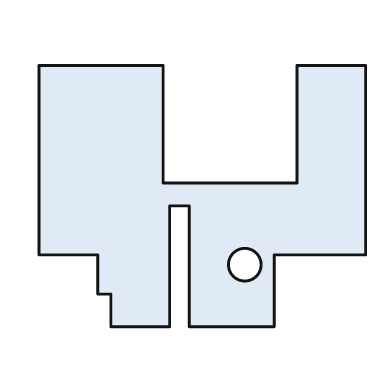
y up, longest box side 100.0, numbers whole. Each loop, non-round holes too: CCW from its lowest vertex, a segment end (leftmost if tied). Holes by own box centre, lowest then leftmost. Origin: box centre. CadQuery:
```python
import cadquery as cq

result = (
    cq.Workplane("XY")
    .moveTo(-28.0, -40.0)
    .lineTo(-10.0, -40.0)
    .lineTo(-10.0, -3.0)
    .lineTo(-4.0, -3.0)
    .lineTo(-4.0, -40.0)
    .lineTo(22.0, -40.0)
    .lineTo(22.0, -18.0)
    .lineTo(50.0, -18.0)
    .lineTo(50.0, 40.0)
    .lineTo(29.0, 40.0)
    .lineTo(29.0, 4.0)
    .lineTo(-12.0, 4.0)
    .lineTo(-12.0, 40.0)
    .lineTo(-50.0, 40.0)
    .lineTo(-50.0, -18.0)
    .lineTo(-32.0, -18.0)
    .lineTo(-32.0, -30.0)
    .lineTo(-28.0, -30.0)
    .close()
    .moveTo(13.0, -21.0)
    .circle(5.0)
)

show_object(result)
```